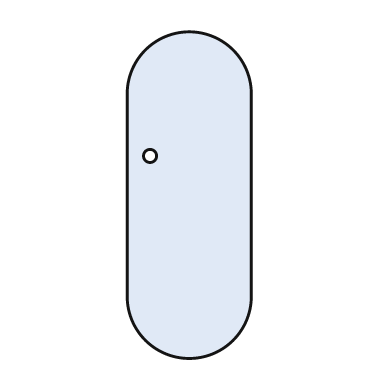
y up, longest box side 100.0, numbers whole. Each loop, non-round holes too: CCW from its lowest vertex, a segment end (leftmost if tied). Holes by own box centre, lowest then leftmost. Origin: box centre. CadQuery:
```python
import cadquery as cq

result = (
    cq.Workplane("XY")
    .moveTo(-19.0, -31.0)
    .threePointArc((0.0, -50.0), (19.0, -31.0))
    .lineTo(19.0, 31.0)
    .threePointArc((0.0, 50.0), (-19.0, 31.0))
    .close()
    .moveTo(-12.0, 12.0)
    .circle(2.0)
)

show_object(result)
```